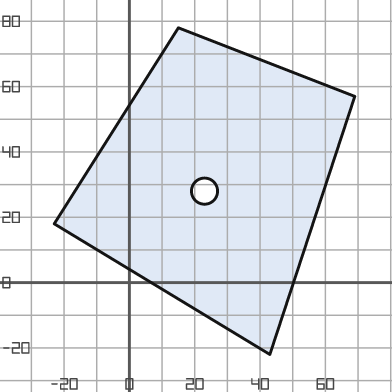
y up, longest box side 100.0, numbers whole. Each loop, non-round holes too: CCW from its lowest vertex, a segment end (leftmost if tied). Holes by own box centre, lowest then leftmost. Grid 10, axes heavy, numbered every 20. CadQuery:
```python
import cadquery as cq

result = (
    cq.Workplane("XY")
    .moveTo(43.0, -22.0)
    .lineTo(69.0, 57.0)
    .lineTo(15.0, 78.0)
    .lineTo(-23.0, 18.0)
    .close()
    .moveTo(23.0, 28.0)
    .circle(4.0)
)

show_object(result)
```